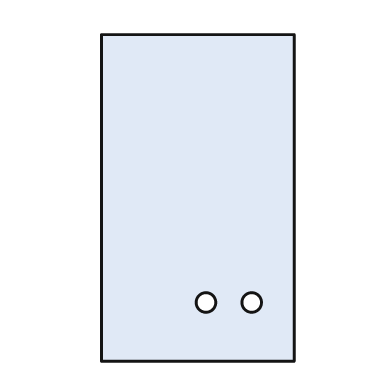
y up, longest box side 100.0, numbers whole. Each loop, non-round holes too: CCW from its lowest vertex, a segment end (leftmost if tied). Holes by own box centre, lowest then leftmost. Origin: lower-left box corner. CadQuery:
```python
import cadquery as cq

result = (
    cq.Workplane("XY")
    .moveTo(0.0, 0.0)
    .lineTo(59.0, 0.0)
    .lineTo(59.0, 100.0)
    .lineTo(0.0, 100.0)
    .close()
    .moveTo(32.0, 18.0)
    .circle(3.0)
    .moveTo(46.0, 18.0)
    .circle(3.0)
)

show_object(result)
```